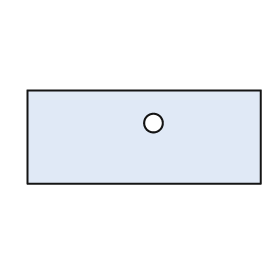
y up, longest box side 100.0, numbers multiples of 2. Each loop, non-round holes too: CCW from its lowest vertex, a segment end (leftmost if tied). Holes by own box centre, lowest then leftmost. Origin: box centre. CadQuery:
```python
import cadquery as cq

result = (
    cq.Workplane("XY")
    .moveTo(-50.0, -20.0)
    .lineTo(50.0, -20.0)
    .lineTo(50.0, 20.0)
    .lineTo(-50.0, 20.0)
    .close()
    .moveTo(4.0, 6.0)
    .circle(4.0)
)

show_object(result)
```